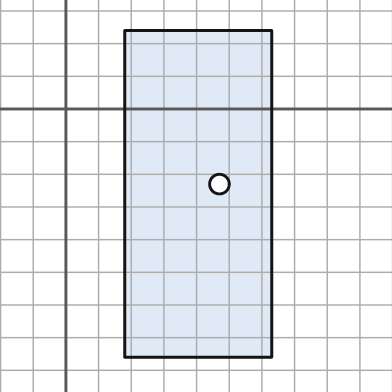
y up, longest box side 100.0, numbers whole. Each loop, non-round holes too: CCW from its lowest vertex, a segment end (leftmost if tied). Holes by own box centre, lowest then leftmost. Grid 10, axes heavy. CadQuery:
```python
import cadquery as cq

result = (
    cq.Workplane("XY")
    .moveTo(18.0, -76.0)
    .lineTo(63.0, -76.0)
    .lineTo(63.0, 24.0)
    .lineTo(18.0, 24.0)
    .close()
    .moveTo(47.0, -23.0)
    .circle(3.0)
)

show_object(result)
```